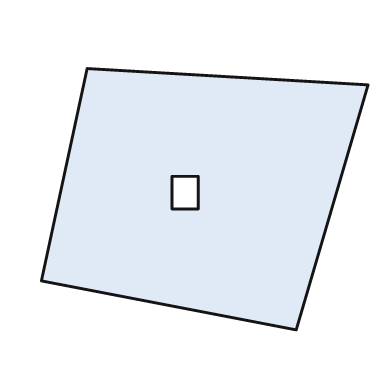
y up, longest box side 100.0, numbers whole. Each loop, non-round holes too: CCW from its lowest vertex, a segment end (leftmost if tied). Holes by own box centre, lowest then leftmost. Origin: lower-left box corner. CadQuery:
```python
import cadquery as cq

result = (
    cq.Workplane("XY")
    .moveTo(78.0, 0.0)
    .lineTo(100.0, 75.0)
    .lineTo(14.0, 80.0)
    .lineTo(0.0, 15.0)
    .close()
    .moveTo(40.0, 37.0)
    .lineTo(48.0, 37.0)
    .lineTo(48.0, 47.0)
    .lineTo(40.0, 47.0)
    .close()
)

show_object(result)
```